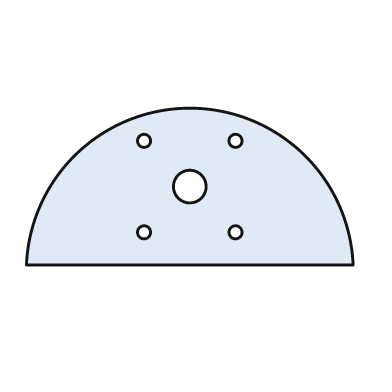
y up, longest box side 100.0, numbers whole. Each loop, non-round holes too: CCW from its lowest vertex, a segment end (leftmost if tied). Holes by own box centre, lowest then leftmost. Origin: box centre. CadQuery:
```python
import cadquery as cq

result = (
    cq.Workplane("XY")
    .moveTo(-50.0, -24.0)
    .lineTo(50.0, -24.0)
    .threePointArc((0.0, 24.0), (-50.0, -24.0))
    .close()
    .moveTo(-14.0, -14.0)
    .circle(2.0)
    .moveTo(14.0, -14.0)
    .circle(2.0)
    .moveTo(0.0, 0.0)
    .circle(5.0)
    .moveTo(-14.0, 14.0)
    .circle(2.0)
    .moveTo(14.0, 14.0)
    .circle(2.0)
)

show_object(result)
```